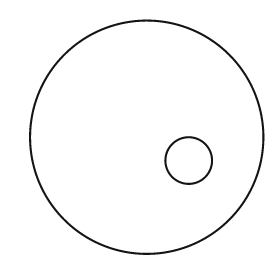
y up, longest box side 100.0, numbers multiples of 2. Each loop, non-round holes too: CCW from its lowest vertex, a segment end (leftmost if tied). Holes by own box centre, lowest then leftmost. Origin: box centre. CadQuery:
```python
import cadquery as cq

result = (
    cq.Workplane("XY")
    .moveTo(0.0, 0.0)
    .circle(50.0)
    .moveTo(18.0, -10.0)
    .circle(10.0)
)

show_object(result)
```